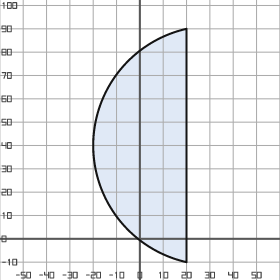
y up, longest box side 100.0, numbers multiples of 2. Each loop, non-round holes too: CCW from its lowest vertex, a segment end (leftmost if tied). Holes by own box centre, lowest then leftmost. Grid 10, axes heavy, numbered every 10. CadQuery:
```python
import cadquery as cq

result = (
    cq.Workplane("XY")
    .moveTo(20.0, -10.0)
    .lineTo(20.0, 90.0)
    .threePointArc((-20.0, 40.0), (20.0, -10.0))
    .close()
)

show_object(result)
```